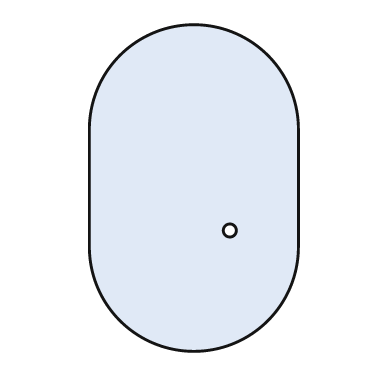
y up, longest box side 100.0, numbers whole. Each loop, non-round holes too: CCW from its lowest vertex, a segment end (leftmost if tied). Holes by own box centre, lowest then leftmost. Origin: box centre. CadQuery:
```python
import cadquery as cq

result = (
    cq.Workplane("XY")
    .moveTo(-32.0, -18.0)
    .threePointArc((0.0, -50.0), (32.0, -18.0))
    .lineTo(32.0, 18.0)
    .threePointArc((0.0, 50.0), (-32.0, 18.0))
    .close()
    .moveTo(11.0, -13.0)
    .circle(2.0)
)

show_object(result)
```